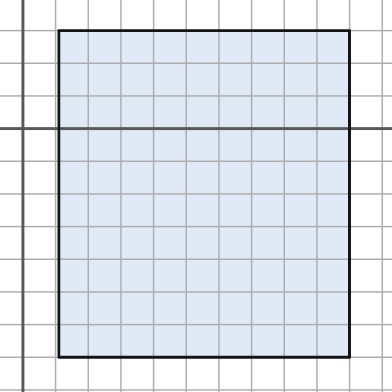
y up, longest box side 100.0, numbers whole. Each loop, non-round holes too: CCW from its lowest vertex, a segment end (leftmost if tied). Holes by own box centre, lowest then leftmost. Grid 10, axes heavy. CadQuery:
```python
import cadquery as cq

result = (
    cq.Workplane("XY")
    .moveTo(11.0, -70.0)
    .lineTo(100.0, -70.0)
    .lineTo(100.0, 30.0)
    .lineTo(11.0, 30.0)
    .close()
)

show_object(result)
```